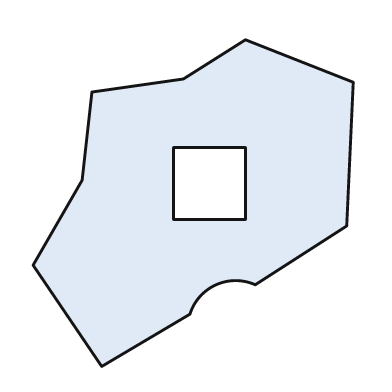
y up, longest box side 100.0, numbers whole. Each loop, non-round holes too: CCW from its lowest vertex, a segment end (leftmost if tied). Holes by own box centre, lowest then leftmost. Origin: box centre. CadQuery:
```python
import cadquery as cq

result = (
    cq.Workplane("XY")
    .moveTo(-28.0, -50.0)
    .lineTo(-1.0, -34.0)
    .threePointArc((7.0, -25.0), (19.0, -25.0))
    .lineTo(47.0, -7.0)
    .lineTo(49.0, 37.0)
    .lineTo(16.0, 50.0)
    .lineTo(-3.0, 38.0)
    .lineTo(-31.0, 34.0)
    .lineTo(-34.0, 7.0)
    .lineTo(-49.0, -19.0)
    .close()
    .moveTo(-6.0, -5.0)
    .lineTo(16.0, -5.0)
    .lineTo(16.0, 17.0)
    .lineTo(-6.0, 17.0)
    .close()
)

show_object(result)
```